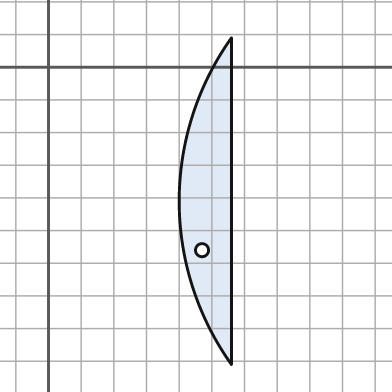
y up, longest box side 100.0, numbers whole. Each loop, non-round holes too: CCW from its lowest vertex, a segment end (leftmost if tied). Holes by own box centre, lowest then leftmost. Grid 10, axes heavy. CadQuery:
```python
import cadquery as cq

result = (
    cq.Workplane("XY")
    .moveTo(56.0, -91.0)
    .lineTo(56.0, 9.0)
    .threePointArc((40.0, -41.0), (56.0, -91.0))
    .close()
    .moveTo(47.0, -56.0)
    .circle(2.0)
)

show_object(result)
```